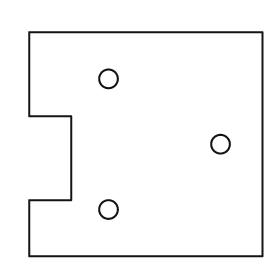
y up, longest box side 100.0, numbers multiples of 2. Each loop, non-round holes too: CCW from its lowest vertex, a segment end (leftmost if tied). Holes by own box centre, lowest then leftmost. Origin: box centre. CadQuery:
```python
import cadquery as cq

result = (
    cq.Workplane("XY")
    .moveTo(-50.0, -48.0)
    .lineTo(50.0, -48.0)
    .lineTo(50.0, 48.0)
    .lineTo(-50.0, 48.0)
    .lineTo(-50.0, 12.0)
    .lineTo(-32.0, 12.0)
    .lineTo(-32.0, -24.0)
    .lineTo(-50.0, -24.0)
    .close()
    .moveTo(-16.0, -28.0)
    .circle(4.0)
    .moveTo(32.0, 0.0)
    .circle(4.0)
    .moveTo(-16.0, 28.0)
    .circle(4.0)
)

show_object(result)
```